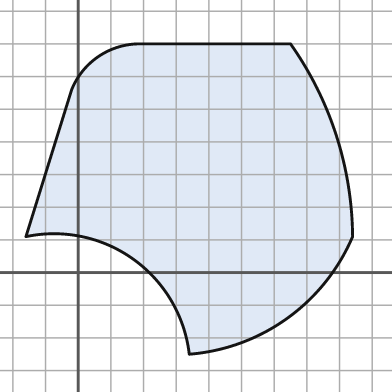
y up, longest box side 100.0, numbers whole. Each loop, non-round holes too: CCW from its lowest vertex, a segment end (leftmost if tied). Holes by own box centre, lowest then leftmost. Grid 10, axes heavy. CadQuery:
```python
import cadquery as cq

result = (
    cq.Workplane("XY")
    .moveTo(34.0, -25.0)
    .threePointArc((64.0, -14.0), (84.0, 11.0))
    .threePointArc((79.0, 42.0), (65.0, 70.0))
    .lineTo(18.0, 70.0)
    .threePointArc((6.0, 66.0), (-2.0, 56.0))
    .lineTo(-16.0, 11.0)
    .threePointArc((17.0, 4.0), (34.0, -25.0))
    .close()
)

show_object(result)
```